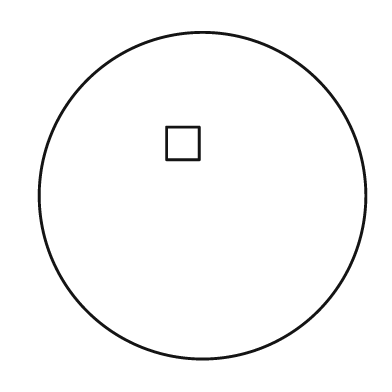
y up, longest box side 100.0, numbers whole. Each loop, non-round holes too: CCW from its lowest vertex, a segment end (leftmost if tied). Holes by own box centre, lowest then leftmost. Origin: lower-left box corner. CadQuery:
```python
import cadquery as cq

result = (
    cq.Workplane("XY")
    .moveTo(50.0, 50.0)
    .circle(50.0)
    .moveTo(39.0, 61.0)
    .lineTo(49.0, 61.0)
    .lineTo(49.0, 71.0)
    .lineTo(39.0, 71.0)
    .close()
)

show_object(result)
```